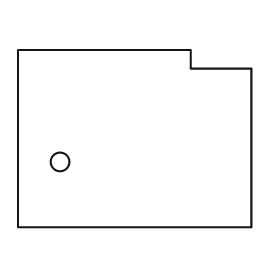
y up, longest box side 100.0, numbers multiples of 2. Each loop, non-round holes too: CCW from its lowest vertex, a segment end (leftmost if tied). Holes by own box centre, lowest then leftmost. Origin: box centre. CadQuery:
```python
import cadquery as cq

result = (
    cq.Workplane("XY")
    .moveTo(-50.0, -38.0)
    .lineTo(50.0, -38.0)
    .lineTo(50.0, 30.0)
    .lineTo(24.0, 30.0)
    .lineTo(24.0, 38.0)
    .lineTo(-50.0, 38.0)
    .close()
    .moveTo(-32.0, -10.0)
    .circle(4.0)
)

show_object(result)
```